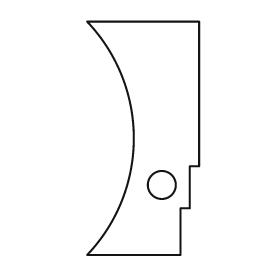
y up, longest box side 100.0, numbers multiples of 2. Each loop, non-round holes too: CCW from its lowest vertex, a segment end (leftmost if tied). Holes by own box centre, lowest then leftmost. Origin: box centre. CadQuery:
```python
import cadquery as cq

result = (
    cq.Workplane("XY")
    .moveTo(-24.0, -50.0)
    .lineTo(16.0, -50.0)
    .lineTo(16.0, -30.0)
    .lineTo(20.0, -30.0)
    .lineTo(20.0, -12.0)
    .lineTo(24.0, -12.0)
    .lineTo(24.0, 50.0)
    .lineTo(-24.0, 50.0)
    .threePointArc((-4.0, 0.0), (-24.0, -50.0))
    .close()
    .moveTo(8.0, -20.0)
    .circle(6.0)
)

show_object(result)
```